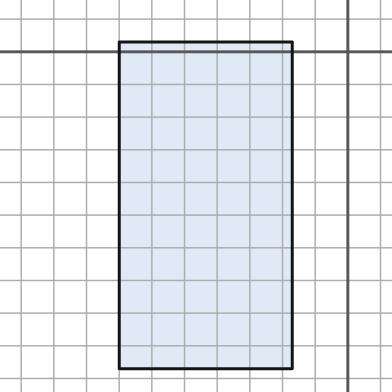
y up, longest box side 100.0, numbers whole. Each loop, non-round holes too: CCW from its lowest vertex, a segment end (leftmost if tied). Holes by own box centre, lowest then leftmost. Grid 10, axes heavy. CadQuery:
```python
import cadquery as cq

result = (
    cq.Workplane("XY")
    .moveTo(-70.0, -97.0)
    .lineTo(-17.0, -97.0)
    .lineTo(-17.0, 3.0)
    .lineTo(-70.0, 3.0)
    .close()
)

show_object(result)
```